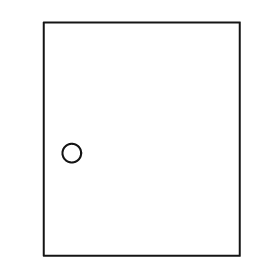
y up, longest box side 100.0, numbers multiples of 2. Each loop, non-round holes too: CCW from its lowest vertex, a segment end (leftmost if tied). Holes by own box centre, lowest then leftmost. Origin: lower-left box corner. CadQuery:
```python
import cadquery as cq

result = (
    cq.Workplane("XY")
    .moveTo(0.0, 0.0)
    .lineTo(84.0, 0.0)
    .lineTo(84.0, 100.0)
    .lineTo(0.0, 100.0)
    .close()
    .moveTo(12.0, 44.0)
    .circle(4.0)
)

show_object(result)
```